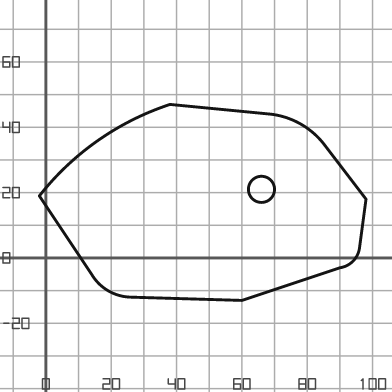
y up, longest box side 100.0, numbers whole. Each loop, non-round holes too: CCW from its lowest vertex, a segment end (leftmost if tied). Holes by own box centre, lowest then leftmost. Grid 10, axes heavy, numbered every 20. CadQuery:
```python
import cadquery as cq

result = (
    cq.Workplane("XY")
    .moveTo(60.0, -13.0)
    .lineTo(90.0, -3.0)
    .threePointArc((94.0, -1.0), (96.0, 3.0))
    .lineTo(98.0, 18.0)
    .lineTo(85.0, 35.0)
    .threePointArc((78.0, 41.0), (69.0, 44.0))
    .lineTo(38.0, 47.0)
    .threePointArc((16.0, 36.0), (-2.0, 19.0))
    .lineTo(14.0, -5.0)
    .threePointArc((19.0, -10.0), (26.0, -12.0))
    .close()
    .moveTo(66.0, 21.0)
    .circle(4.0)
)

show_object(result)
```